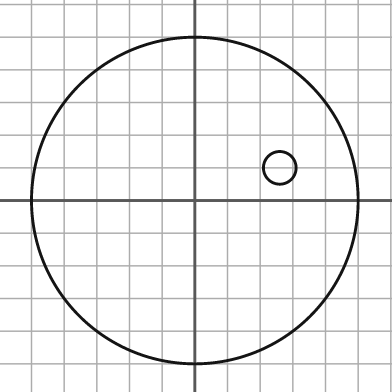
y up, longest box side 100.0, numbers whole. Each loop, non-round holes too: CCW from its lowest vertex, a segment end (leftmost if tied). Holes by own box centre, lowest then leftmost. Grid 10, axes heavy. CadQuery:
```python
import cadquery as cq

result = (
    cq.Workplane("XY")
    .moveTo(0.0, 0.0)
    .circle(50.0)
    .moveTo(26.0, 10.0)
    .circle(5.0)
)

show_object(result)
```